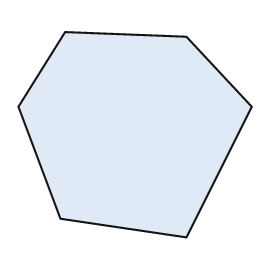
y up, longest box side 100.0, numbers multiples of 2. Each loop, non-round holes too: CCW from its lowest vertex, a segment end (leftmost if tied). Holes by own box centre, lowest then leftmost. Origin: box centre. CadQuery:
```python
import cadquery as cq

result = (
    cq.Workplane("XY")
    .moveTo(22.0, -44.0)
    .lineTo(50.0, 12.0)
    .lineTo(22.0, 42.0)
    .lineTo(-30.0, 44.0)
    .lineTo(-50.0, 12.0)
    .lineTo(-32.0, -36.0)
    .close()
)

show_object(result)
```